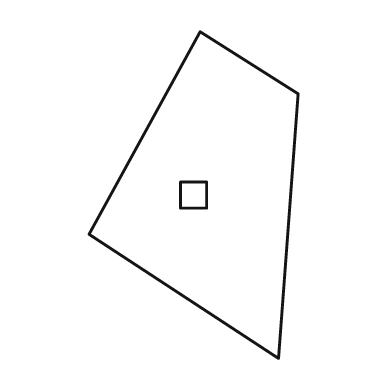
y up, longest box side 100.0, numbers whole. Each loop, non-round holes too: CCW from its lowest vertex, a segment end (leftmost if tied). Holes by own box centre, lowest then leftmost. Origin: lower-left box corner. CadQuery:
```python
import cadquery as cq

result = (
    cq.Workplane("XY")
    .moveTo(58.0, 0.0)
    .lineTo(64.0, 81.0)
    .lineTo(34.0, 100.0)
    .lineTo(0.0, 38.0)
    .close()
    .moveTo(28.0, 46.0)
    .lineTo(36.0, 46.0)
    .lineTo(36.0, 54.0)
    .lineTo(28.0, 54.0)
    .close()
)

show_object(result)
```